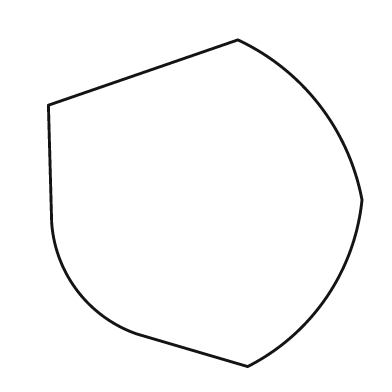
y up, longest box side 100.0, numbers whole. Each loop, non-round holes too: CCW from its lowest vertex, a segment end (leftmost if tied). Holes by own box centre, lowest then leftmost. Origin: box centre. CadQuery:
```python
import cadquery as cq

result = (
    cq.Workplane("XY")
    .moveTo(13.0, -50.0)
    .threePointArc((37.0, -29.0), (48.0, 1.0))
    .threePointArc((35.0, 30.0), (10.0, 50.0))
    .lineTo(-48.0, 30.0)
    .lineTo(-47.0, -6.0)
    .threePointArc((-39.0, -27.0), (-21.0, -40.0))
    .close()
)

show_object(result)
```